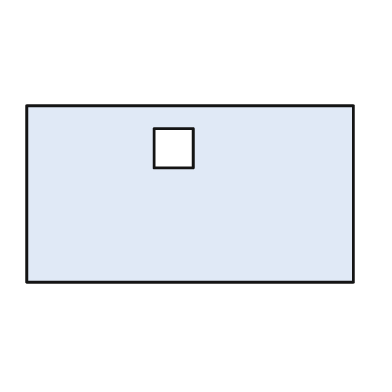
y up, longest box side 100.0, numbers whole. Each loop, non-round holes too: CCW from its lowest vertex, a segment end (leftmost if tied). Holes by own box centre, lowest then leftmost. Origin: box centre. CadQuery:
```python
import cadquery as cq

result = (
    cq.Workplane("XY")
    .moveTo(-50.0, -27.0)
    .lineTo(50.0, -27.0)
    .lineTo(50.0, 27.0)
    .lineTo(-50.0, 27.0)
    .close()
    .moveTo(-11.0, 8.0)
    .lineTo(1.0, 8.0)
    .lineTo(1.0, 20.0)
    .lineTo(-11.0, 20.0)
    .close()
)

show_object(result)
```